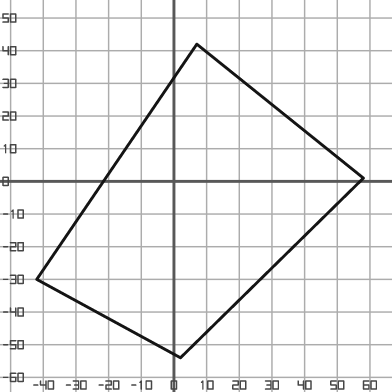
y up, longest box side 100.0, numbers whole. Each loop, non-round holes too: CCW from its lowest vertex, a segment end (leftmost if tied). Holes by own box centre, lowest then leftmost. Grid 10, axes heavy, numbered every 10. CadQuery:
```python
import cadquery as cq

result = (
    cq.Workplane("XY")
    .moveTo(2.0, -54.0)
    .lineTo(58.0, 1.0)
    .lineTo(7.0, 42.0)
    .lineTo(-42.0, -30.0)
    .close()
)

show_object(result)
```